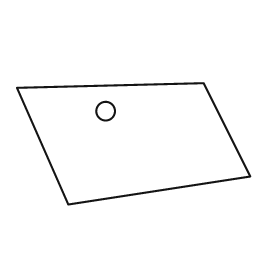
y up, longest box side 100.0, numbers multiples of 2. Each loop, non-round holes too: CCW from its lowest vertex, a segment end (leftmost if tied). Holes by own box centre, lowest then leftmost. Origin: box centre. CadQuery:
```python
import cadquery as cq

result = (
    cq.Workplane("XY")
    .moveTo(-28.0, -26.0)
    .lineTo(50.0, -14.0)
    .lineTo(30.0, 26.0)
    .lineTo(-50.0, 24.0)
    .close()
    .moveTo(-12.0, 14.0)
    .circle(4.0)
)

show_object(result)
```